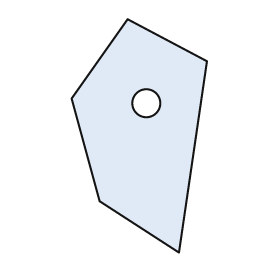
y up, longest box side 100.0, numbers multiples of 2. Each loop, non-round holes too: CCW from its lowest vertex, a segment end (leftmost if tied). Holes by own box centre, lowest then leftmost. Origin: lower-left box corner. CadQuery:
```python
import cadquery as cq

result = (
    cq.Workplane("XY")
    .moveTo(46.0, 0.0)
    .lineTo(58.0, 82.0)
    .lineTo(24.0, 100.0)
    .lineTo(0.0, 66.0)
    .lineTo(12.0, 22.0)
    .close()
    .moveTo(32.0, 64.0)
    .circle(6.0)
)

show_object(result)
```